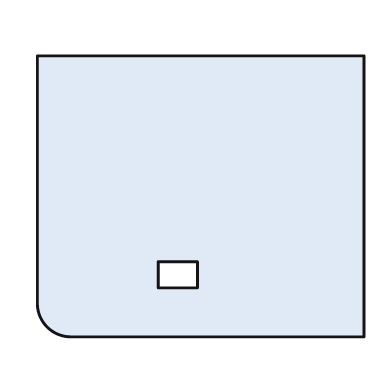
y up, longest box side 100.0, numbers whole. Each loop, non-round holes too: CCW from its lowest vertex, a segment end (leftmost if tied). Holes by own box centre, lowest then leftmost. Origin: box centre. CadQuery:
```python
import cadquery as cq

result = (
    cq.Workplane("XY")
    .moveTo(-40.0, -43.0)
    .lineTo(50.0, -43.0)
    .lineTo(50.0, 43.0)
    .lineTo(-50.0, 43.0)
    .lineTo(-50.0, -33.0)
    .threePointArc((-47.0, -40.0), (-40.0, -43.0))
    .close()
    .moveTo(-13.0, -28.0)
    .lineTo(-1.0, -28.0)
    .lineTo(-1.0, -20.0)
    .lineTo(-13.0, -20.0)
    .close()
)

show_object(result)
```